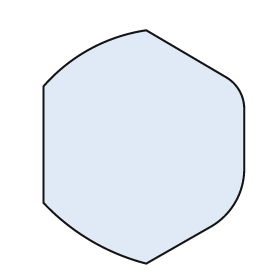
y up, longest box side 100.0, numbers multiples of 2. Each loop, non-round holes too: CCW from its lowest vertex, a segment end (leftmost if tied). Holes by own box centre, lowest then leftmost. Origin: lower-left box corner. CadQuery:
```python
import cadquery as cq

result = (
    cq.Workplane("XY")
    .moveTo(44.0, 0.0)
    .lineTo(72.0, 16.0)
    .threePointArc((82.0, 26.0), (86.0, 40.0))
    .lineTo(86.0, 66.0)
    .threePointArc((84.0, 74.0), (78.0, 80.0))
    .lineTo(44.0, 100.0)
    .threePointArc((20.0, 92.0), (0.0, 76.0))
    .lineTo(0.0, 26.0)
    .threePointArc((20.0, 10.0), (44.0, 0.0))
    .close()
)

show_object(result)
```